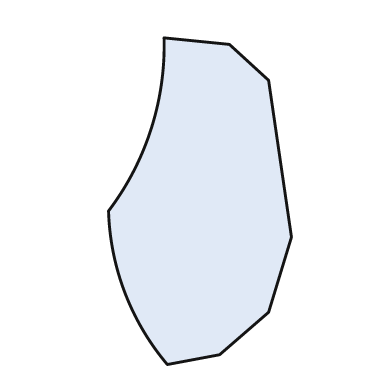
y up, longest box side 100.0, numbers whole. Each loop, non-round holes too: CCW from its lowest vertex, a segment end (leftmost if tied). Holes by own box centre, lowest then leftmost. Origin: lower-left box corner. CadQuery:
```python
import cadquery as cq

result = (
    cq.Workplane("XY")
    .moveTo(18.0, 0.0)
    .lineTo(34.0, 3.0)
    .lineTo(49.0, 16.0)
    .lineTo(56.0, 39.0)
    .lineTo(49.0, 87.0)
    .lineTo(37.0, 98.0)
    .lineTo(17.0, 100.0)
    .threePointArc((13.0, 72.0), (0.0, 47.0))
    .threePointArc((5.0, 22.0), (18.0, 0.0))
    .close()
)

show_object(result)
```